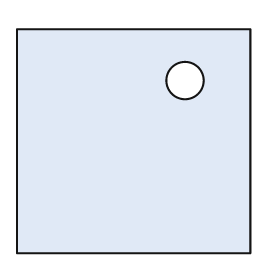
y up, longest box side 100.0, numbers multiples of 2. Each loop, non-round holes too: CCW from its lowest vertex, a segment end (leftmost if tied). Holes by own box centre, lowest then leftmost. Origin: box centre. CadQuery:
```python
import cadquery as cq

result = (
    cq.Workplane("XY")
    .moveTo(-50.0, -48.0)
    .lineTo(50.0, -48.0)
    .lineTo(50.0, 48.0)
    .lineTo(-50.0, 48.0)
    .close()
    .moveTo(22.0, 26.0)
    .circle(8.0)
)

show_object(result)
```